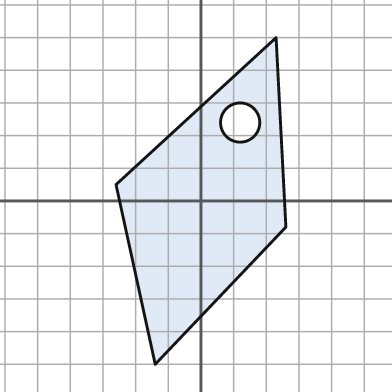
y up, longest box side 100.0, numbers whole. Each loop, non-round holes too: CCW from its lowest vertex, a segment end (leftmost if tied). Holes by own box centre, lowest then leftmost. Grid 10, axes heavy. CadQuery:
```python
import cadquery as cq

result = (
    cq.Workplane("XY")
    .moveTo(-14.0, -50.0)
    .lineTo(26.0, -8.0)
    .lineTo(23.0, 50.0)
    .lineTo(-26.0, 5.0)
    .close()
    .moveTo(12.0, 24.0)
    .circle(6.0)
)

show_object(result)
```